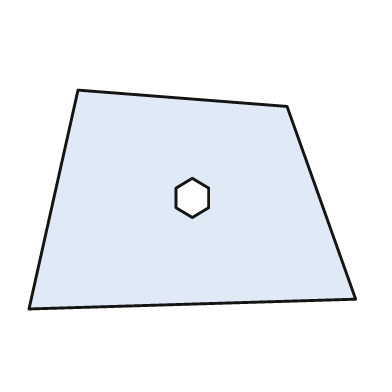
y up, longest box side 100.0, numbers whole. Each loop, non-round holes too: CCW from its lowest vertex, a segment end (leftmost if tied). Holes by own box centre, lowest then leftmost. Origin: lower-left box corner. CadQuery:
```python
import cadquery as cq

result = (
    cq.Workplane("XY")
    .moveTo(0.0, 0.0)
    .lineTo(100.0, 3.0)
    .lineTo(79.0, 62.0)
    .lineTo(15.0, 67.0)
    .close()
    .moveTo(50.0, 28.0)
    .lineTo(55.0, 31.0)
    .lineTo(55.0, 37.0)
    .lineTo(50.0, 40.0)
    .lineTo(45.0, 37.0)
    .lineTo(45.0, 31.0)
    .close()
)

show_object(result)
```